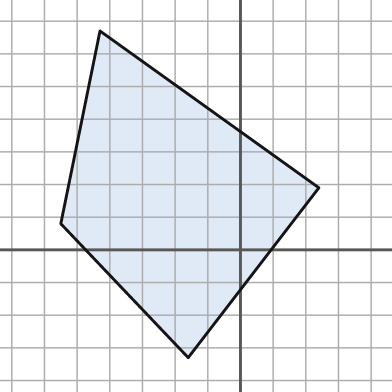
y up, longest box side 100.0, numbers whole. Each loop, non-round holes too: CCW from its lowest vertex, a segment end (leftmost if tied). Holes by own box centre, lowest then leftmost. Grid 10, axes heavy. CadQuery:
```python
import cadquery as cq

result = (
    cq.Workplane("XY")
    .moveTo(-16.0, -33.0)
    .lineTo(24.0, 19.0)
    .lineTo(-43.0, 67.0)
    .lineTo(-55.0, 8.0)
    .close()
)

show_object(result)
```